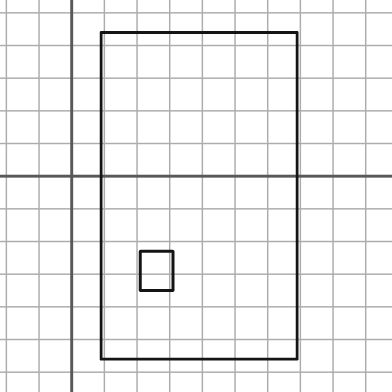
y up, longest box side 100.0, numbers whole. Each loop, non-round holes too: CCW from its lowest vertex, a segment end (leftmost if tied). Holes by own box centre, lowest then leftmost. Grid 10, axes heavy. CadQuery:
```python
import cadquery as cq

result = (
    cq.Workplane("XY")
    .moveTo(9.0, -56.0)
    .lineTo(69.0, -56.0)
    .lineTo(69.0, 44.0)
    .lineTo(9.0, 44.0)
    .close()
    .moveTo(21.0, -35.0)
    .lineTo(31.0, -35.0)
    .lineTo(31.0, -23.0)
    .lineTo(21.0, -23.0)
    .close()
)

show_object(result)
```